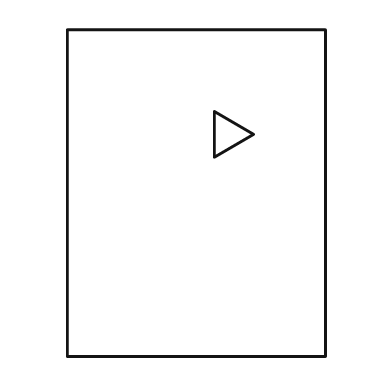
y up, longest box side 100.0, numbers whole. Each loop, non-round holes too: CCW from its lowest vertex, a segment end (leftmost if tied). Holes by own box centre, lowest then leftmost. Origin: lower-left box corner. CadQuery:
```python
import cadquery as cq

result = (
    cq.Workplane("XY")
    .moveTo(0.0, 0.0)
    .lineTo(79.0, 0.0)
    .lineTo(79.0, 100.0)
    .lineTo(0.0, 100.0)
    .close()
    .moveTo(45.0, 61.0)
    .lineTo(57.0, 68.0)
    .lineTo(45.0, 75.0)
    .close()
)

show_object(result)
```